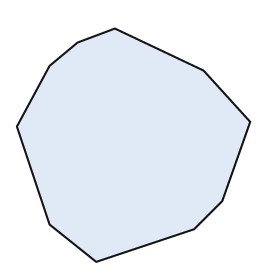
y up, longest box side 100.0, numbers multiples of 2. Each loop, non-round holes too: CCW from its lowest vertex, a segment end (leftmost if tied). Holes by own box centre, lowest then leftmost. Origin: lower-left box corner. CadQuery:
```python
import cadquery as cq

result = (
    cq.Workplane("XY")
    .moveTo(34.0, 0.0)
    .lineTo(76.0, 14.0)
    .lineTo(88.0, 26.0)
    .lineTo(100.0, 60.0)
    .lineTo(80.0, 82.0)
    .lineTo(42.0, 100.0)
    .lineTo(26.0, 94.0)
    .lineTo(14.0, 84.0)
    .lineTo(0.0, 58.0)
    .lineTo(14.0, 16.0)
    .close()
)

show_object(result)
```